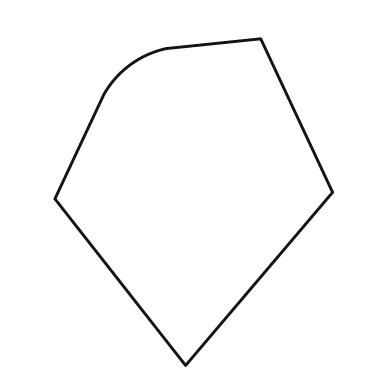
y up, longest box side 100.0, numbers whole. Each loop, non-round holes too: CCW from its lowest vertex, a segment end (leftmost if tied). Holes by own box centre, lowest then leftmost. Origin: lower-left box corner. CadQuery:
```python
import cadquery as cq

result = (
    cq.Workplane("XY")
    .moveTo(40.0, 0.0)
    .lineTo(85.0, 53.0)
    .lineTo(63.0, 100.0)
    .lineTo(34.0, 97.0)
    .threePointArc((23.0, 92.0), (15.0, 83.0))
    .lineTo(0.0, 51.0)
    .close()
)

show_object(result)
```